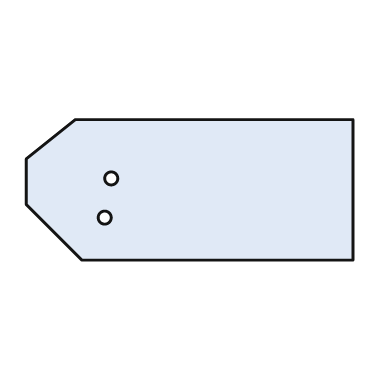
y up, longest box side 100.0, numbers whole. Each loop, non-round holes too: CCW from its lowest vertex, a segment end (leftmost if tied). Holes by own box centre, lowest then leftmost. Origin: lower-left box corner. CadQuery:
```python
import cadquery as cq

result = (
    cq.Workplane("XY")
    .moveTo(17.0, 0.0)
    .lineTo(100.0, 0.0)
    .lineTo(100.0, 43.0)
    .lineTo(15.0, 43.0)
    .lineTo(0.0, 31.0)
    .lineTo(0.0, 17.0)
    .close()
    .moveTo(24.0, 13.0)
    .circle(2.0)
    .moveTo(26.0, 25.0)
    .circle(2.0)
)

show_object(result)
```